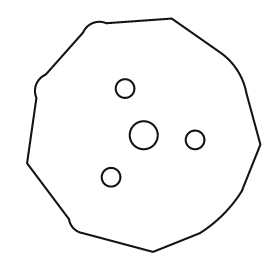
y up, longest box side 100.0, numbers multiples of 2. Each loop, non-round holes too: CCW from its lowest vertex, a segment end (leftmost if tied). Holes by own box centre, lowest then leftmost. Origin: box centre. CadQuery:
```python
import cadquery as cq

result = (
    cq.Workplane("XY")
    .moveTo(4.0, -50.0)
    .lineTo(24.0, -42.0)
    .threePointArc((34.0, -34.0), (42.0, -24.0))
    .lineTo(50.0, -4.0)
    .lineTo(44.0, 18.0)
    .threePointArc((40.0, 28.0), (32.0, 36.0))
    .lineTo(12.0, 50.0)
    .lineTo(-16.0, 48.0)
    .threePointArc((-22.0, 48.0), (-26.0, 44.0))
    .lineTo(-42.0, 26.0)
    .threePointArc((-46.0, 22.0), (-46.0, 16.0))
    .lineTo(-50.0, -12.0)
    .lineTo(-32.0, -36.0)
    .threePointArc((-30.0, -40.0), (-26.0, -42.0))
    .close()
    .moveTo(-14.0, -18.0)
    .circle(4.0)
    .moveTo(22.0, -2.0)
    .circle(4.0)
    .moveTo(0.0, 0.0)
    .circle(6.0)
    .moveTo(-8.0, 20.0)
    .circle(4.0)
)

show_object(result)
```